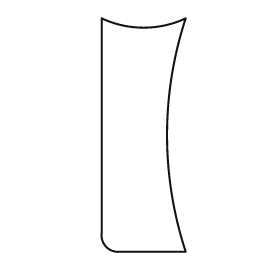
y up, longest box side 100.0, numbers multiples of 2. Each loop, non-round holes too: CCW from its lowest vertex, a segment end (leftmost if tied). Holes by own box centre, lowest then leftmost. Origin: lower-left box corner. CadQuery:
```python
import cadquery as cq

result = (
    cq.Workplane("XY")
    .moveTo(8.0, 0.0)
    .lineTo(36.0, 0.0)
    .threePointArc((28.0, 50.0), (36.0, 100.0))
    .threePointArc((18.0, 96.0), (0.0, 100.0))
    .lineTo(0.0, 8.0)
    .threePointArc((2.0, 2.0), (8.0, 0.0))
    .close()
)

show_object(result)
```